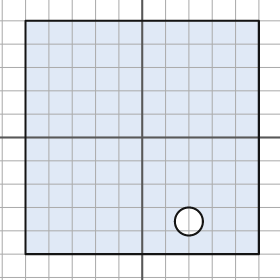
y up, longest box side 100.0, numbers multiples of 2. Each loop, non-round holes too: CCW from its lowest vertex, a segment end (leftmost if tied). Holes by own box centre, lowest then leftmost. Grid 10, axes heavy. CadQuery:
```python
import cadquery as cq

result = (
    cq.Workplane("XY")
    .moveTo(-50.0, -50.0)
    .lineTo(50.0, -50.0)
    .lineTo(50.0, 50.0)
    .lineTo(-50.0, 50.0)
    .close()
    .moveTo(20.0, -36.0)
    .circle(6.0)
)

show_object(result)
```